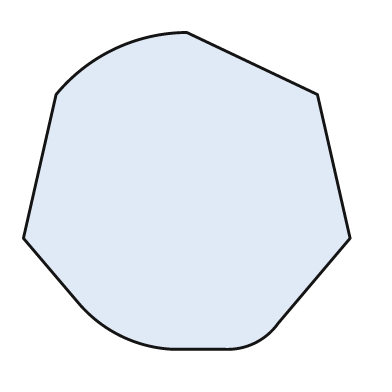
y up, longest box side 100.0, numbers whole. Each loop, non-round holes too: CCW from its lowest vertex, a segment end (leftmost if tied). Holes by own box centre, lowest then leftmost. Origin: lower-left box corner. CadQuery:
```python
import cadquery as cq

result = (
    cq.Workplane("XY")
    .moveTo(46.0, 0.0)
    .lineTo(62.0, 0.0)
    .threePointArc((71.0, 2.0), (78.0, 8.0))
    .lineTo(100.0, 34.0)
    .lineTo(90.0, 78.0)
    .lineTo(50.0, 97.0)
    .threePointArc((28.0, 92.0), (10.0, 78.0))
    .lineTo(0.0, 34.0)
    .lineTo(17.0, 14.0)
    .threePointArc((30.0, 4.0), (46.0, 0.0))
    .close()
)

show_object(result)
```